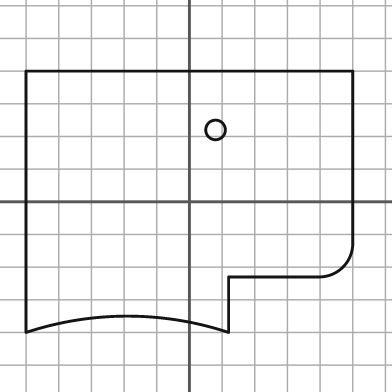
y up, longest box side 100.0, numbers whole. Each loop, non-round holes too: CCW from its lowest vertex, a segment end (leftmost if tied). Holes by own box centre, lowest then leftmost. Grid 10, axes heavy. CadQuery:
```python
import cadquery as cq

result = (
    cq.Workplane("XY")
    .moveTo(-50.0, -40.0)
    .threePointArc((-19.0, -35.0), (12.0, -40.0))
    .lineTo(12.0, -23.0)
    .lineTo(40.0, -23.0)
    .threePointArc((47.0, -20.0), (50.0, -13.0))
    .lineTo(50.0, 40.0)
    .lineTo(-50.0, 40.0)
    .close()
    .moveTo(8.0, 22.0)
    .circle(3.0)
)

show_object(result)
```